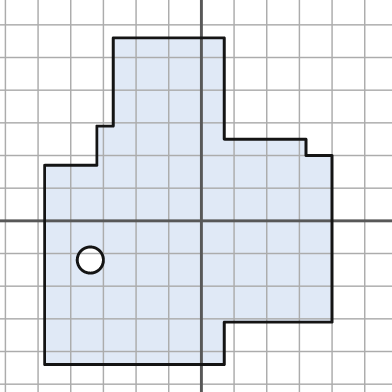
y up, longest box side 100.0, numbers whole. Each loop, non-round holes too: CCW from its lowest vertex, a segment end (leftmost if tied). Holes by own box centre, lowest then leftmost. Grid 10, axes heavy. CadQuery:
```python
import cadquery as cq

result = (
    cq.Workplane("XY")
    .moveTo(-48.0, -44.0)
    .lineTo(7.0, -44.0)
    .lineTo(7.0, -31.0)
    .lineTo(40.0, -31.0)
    .lineTo(40.0, 20.0)
    .lineTo(32.0, 20.0)
    .lineTo(32.0, 25.0)
    .lineTo(7.0, 25.0)
    .lineTo(7.0, 56.0)
    .lineTo(-27.0, 56.0)
    .lineTo(-27.0, 29.0)
    .lineTo(-32.0, 29.0)
    .lineTo(-32.0, 17.0)
    .lineTo(-48.0, 17.0)
    .close()
    .moveTo(-34.0, -12.0)
    .circle(4.0)
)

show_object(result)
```